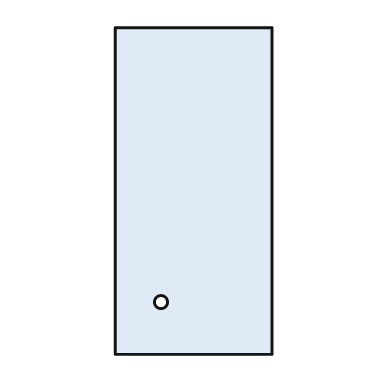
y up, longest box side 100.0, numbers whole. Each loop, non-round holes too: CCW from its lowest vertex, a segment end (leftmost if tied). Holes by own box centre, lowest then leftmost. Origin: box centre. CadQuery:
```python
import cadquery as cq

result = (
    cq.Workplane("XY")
    .moveTo(-24.0, -50.0)
    .lineTo(24.0, -50.0)
    .lineTo(24.0, 50.0)
    .lineTo(-24.0, 50.0)
    .close()
    .moveTo(-10.0, -34.0)
    .circle(2.0)
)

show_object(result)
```